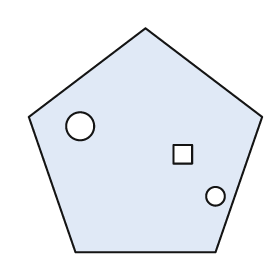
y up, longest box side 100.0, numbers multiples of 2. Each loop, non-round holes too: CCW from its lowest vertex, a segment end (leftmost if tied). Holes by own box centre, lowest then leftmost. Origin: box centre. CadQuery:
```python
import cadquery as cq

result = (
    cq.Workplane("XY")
    .moveTo(-30.0, -48.0)
    .lineTo(30.0, -48.0)
    .lineTo(50.0, 10.0)
    .lineTo(0.0, 48.0)
    .lineTo(-50.0, 10.0)
    .close()
    .moveTo(30.0, -24.0)
    .circle(4.0)
    .moveTo(12.0, -10.0)
    .lineTo(20.0, -10.0)
    .lineTo(20.0, -2.0)
    .lineTo(12.0, -2.0)
    .close()
    .moveTo(-28.0, 6.0)
    .circle(6.0)
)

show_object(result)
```